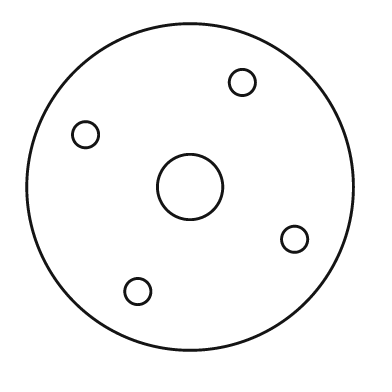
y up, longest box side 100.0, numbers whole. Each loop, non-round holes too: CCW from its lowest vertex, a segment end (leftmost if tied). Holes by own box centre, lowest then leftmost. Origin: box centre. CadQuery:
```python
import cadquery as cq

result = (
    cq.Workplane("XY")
    .moveTo(0.0, 0.0)
    .circle(50.0)
    .moveTo(-16.0, -32.0)
    .circle(4.0)
    .moveTo(32.0, -16.0)
    .circle(4.0)
    .moveTo(0.0, 0.0)
    .circle(10.0)
    .moveTo(-32.0, 16.0)
    .circle(4.0)
    .moveTo(16.0, 32.0)
    .circle(4.0)
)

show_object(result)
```